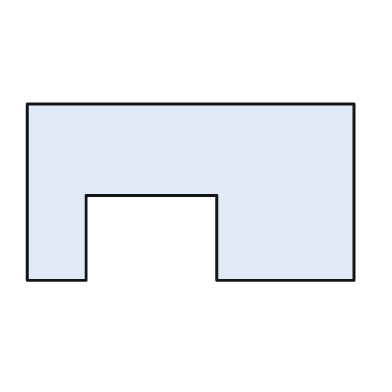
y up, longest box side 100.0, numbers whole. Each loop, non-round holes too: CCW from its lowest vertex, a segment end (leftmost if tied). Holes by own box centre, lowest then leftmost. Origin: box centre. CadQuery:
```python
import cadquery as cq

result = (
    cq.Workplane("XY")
    .moveTo(-50.0, -27.0)
    .lineTo(-32.0, -27.0)
    .lineTo(-32.0, -1.0)
    .lineTo(8.0, -1.0)
    .lineTo(8.0, -27.0)
    .lineTo(50.0, -27.0)
    .lineTo(50.0, 27.0)
    .lineTo(-50.0, 27.0)
    .close()
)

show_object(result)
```